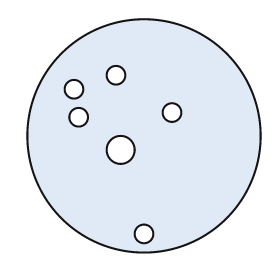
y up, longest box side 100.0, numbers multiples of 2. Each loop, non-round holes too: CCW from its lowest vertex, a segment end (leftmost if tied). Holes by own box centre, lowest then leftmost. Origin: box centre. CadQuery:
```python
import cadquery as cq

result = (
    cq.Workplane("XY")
    .moveTo(0.0, 0.0)
    .circle(50.0)
    .moveTo(0.0, -42.0)
    .circle(4.0)
    .moveTo(-10.0, -6.0)
    .circle(6.0)
    .moveTo(-28.0, 8.0)
    .circle(4.0)
    .moveTo(12.0, 10.0)
    .circle(4.0)
    .moveTo(-30.0, 20.0)
    .circle(4.0)
    .moveTo(-12.0, 26.0)
    .circle(4.0)
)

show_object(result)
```